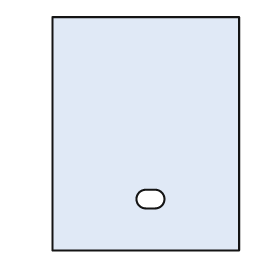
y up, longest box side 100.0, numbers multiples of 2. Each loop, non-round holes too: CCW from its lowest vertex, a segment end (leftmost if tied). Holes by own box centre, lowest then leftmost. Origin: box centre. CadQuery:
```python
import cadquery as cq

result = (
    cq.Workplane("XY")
    .moveTo(-40.0, -50.0)
    .lineTo(40.0, -50.0)
    .lineTo(40.0, 50.0)
    .lineTo(-40.0, 50.0)
    .close()
    .moveTo(0.0, -32.0)
    .lineTo(4.0, -32.0)
    .threePointArc((8.0, -28.0), (4.0, -24.0))
    .lineTo(0.0, -24.0)
    .threePointArc((-4.0, -28.0), (0.0, -32.0))
    .close()
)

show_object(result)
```